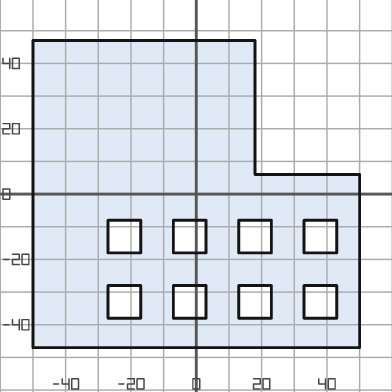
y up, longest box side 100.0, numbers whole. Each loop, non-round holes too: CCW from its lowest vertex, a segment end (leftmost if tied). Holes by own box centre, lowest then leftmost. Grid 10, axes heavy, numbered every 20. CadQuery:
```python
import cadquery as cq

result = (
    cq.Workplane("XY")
    .moveTo(-50.0, -47.0)
    .lineTo(50.0, -47.0)
    .lineTo(50.0, 6.0)
    .lineTo(18.0, 6.0)
    .lineTo(18.0, 47.0)
    .lineTo(-50.0, 47.0)
    .close()
    .moveTo(-27.0, -38.0)
    .lineTo(-17.0, -38.0)
    .lineTo(-17.0, -28.0)
    .lineTo(-27.0, -28.0)
    .close()
    .moveTo(-7.0, -38.0)
    .lineTo(3.0, -38.0)
    .lineTo(3.0, -28.0)
    .lineTo(-7.0, -28.0)
    .close()
    .moveTo(13.0, -38.0)
    .lineTo(23.0, -38.0)
    .lineTo(23.0, -28.0)
    .lineTo(13.0, -28.0)
    .close()
    .moveTo(33.0, -38.0)
    .lineTo(43.0, -38.0)
    .lineTo(43.0, -28.0)
    .lineTo(33.0, -28.0)
    .close()
    .moveTo(-27.0, -18.0)
    .lineTo(-17.0, -18.0)
    .lineTo(-17.0, -8.0)
    .lineTo(-27.0, -8.0)
    .close()
    .moveTo(-7.0, -18.0)
    .lineTo(3.0, -18.0)
    .lineTo(3.0, -8.0)
    .lineTo(-7.0, -8.0)
    .close()
    .moveTo(13.0, -18.0)
    .lineTo(23.0, -18.0)
    .lineTo(23.0, -8.0)
    .lineTo(13.0, -8.0)
    .close()
    .moveTo(33.0, -18.0)
    .lineTo(43.0, -18.0)
    .lineTo(43.0, -8.0)
    .lineTo(33.0, -8.0)
    .close()
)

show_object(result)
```